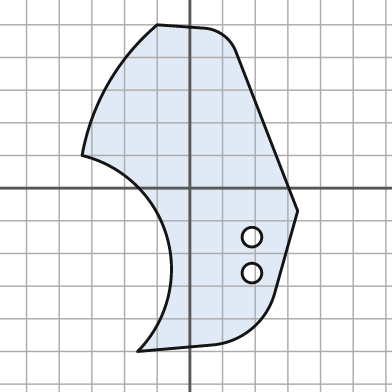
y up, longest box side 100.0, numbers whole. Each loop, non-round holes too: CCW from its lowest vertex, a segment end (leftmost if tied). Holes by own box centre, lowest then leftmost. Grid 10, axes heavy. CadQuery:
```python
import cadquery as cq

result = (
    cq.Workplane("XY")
    .moveTo(-16.0, -50.0)
    .lineTo(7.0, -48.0)
    .threePointArc((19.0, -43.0), (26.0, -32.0))
    .lineTo(33.0, -7.0)
    .lineTo(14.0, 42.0)
    .threePointArc((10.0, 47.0), (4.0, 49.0))
    .lineTo(-10.0, 50.0)
    .threePointArc((-25.0, 32.0), (-33.0, 10.0))
    .threePointArc((-7.0, -15.0), (-16.0, -50.0))
    .close()
    .moveTo(19.0, -26.0)
    .circle(3.0)
    .moveTo(19.0, -15.0)
    .circle(3.0)
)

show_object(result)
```